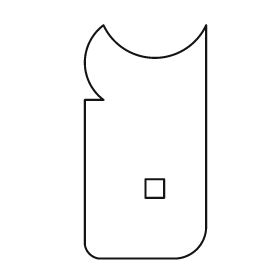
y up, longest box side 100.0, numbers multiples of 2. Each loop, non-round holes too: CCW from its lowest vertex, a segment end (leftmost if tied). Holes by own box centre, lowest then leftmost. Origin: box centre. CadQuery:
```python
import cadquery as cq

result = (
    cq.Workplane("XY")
    .moveTo(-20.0, -50.0)
    .lineTo(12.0, -50.0)
    .threePointArc((22.0, -46.0), (26.0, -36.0))
    .lineTo(26.0, 50.0)
    .threePointArc((4.0, 36.0), (-18.0, 50.0))
    .threePointArc((-26.0, 34.0), (-18.0, 18.0))
    .lineTo(-26.0, 18.0)
    .lineTo(-26.0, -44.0)
    .threePointArc((-24.0, -48.0), (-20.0, -50.0))
    .close()
    .moveTo(0.0, -24.0)
    .lineTo(8.0, -24.0)
    .lineTo(8.0, -16.0)
    .lineTo(0.0, -16.0)
    .close()
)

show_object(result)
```